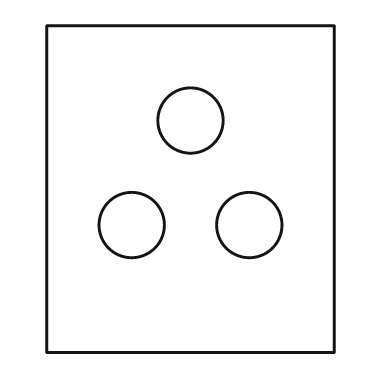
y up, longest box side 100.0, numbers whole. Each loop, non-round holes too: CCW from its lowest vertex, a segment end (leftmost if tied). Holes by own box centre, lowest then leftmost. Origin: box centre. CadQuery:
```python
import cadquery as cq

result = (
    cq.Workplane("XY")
    .moveTo(-44.0, -50.0)
    .lineTo(44.0, -50.0)
    .lineTo(44.0, 50.0)
    .lineTo(-44.0, 50.0)
    .close()
    .moveTo(-18.0, -11.0)
    .circle(10.0)
    .moveTo(18.0, -11.0)
    .circle(10.0)
    .moveTo(0.0, 21.0)
    .circle(10.0)
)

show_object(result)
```